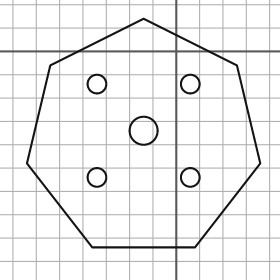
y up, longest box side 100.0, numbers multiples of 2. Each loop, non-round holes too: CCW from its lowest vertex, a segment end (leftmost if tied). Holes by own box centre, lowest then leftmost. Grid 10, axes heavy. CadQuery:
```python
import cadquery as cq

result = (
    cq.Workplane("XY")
    .moveTo(-36.0, -84.0)
    .lineTo(8.0, -84.0)
    .lineTo(36.0, -48.0)
    .lineTo(26.0, -6.0)
    .lineTo(-14.0, 14.0)
    .lineTo(-54.0, -6.0)
    .lineTo(-64.0, -48.0)
    .close()
    .moveTo(-34.0, -54.0)
    .circle(4.0)
    .moveTo(6.0, -54.0)
    .circle(4.0)
    .moveTo(-14.0, -34.0)
    .circle(6.0)
    .moveTo(-34.0, -14.0)
    .circle(4.0)
    .moveTo(6.0, -14.0)
    .circle(4.0)
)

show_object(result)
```